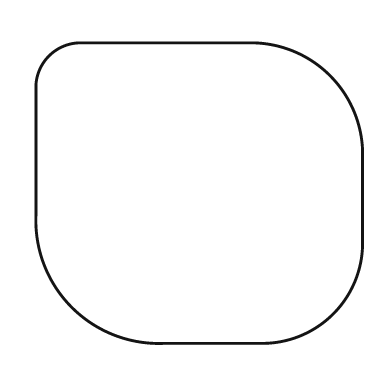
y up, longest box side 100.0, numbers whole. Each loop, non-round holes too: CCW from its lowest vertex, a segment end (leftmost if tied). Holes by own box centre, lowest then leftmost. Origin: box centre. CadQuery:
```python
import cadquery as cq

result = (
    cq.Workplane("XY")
    .moveTo(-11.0, -46.0)
    .lineTo(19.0, -46.0)
    .threePointArc((41.0, -37.0), (50.0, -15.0))
    .lineTo(50.0, 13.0)
    .threePointArc((40.0, 36.0), (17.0, 46.0))
    .lineTo(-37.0, 46.0)
    .threePointArc((-46.0, 42.0), (-50.0, 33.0))
    .lineTo(-50.0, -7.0)
    .threePointArc((-39.0, -35.0), (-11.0, -46.0))
    .close()
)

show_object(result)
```